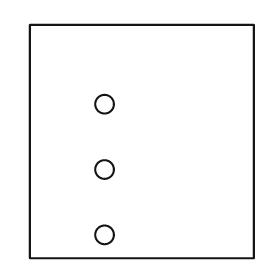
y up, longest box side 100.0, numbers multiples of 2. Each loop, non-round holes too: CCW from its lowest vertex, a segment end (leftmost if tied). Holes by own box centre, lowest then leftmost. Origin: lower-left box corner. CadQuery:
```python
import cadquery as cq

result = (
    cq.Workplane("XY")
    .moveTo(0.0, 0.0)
    .lineTo(96.0, 0.0)
    .lineTo(96.0, 100.0)
    .lineTo(0.0, 100.0)
    .close()
    .moveTo(32.0, 10.0)
    .circle(4.0)
    .moveTo(32.0, 38.0)
    .circle(4.0)
    .moveTo(32.0, 66.0)
    .circle(4.0)
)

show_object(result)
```